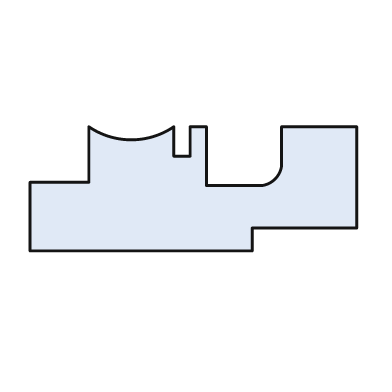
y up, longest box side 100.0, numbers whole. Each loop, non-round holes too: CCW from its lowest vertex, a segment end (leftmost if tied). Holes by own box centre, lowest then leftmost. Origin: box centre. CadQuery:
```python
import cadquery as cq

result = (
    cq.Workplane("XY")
    .moveTo(-50.0, -19.0)
    .lineTo(18.0, -19.0)
    .lineTo(18.0, -12.0)
    .lineTo(50.0, -12.0)
    .lineTo(50.0, 19.0)
    .lineTo(27.0, 19.0)
    .lineTo(27.0, 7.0)
    .threePointArc((25.0, 3.0), (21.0, 1.0))
    .lineTo(4.0, 1.0)
    .lineTo(4.0, 19.0)
    .lineTo(-1.0, 19.0)
    .lineTo(-1.0, 10.0)
    .lineTo(-6.0, 10.0)
    .lineTo(-6.0, 19.0)
    .threePointArc((-19.0, 15.0), (-32.0, 19.0))
    .lineTo(-32.0, 2.0)
    .lineTo(-50.0, 2.0)
    .close()
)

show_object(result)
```